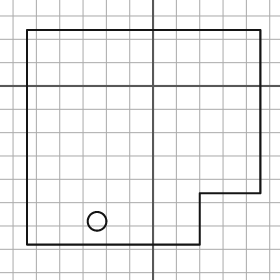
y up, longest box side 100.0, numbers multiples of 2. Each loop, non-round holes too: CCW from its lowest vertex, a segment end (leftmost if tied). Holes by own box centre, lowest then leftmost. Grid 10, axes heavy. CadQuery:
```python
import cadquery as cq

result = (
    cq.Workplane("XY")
    .moveTo(-54.0, -68.0)
    .lineTo(20.0, -68.0)
    .lineTo(20.0, -46.0)
    .lineTo(46.0, -46.0)
    .lineTo(46.0, 24.0)
    .lineTo(-54.0, 24.0)
    .close()
    .moveTo(-24.0, -58.0)
    .circle(4.0)
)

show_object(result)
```